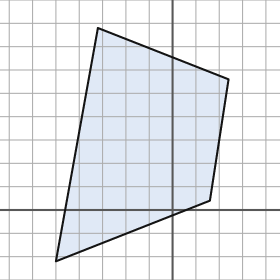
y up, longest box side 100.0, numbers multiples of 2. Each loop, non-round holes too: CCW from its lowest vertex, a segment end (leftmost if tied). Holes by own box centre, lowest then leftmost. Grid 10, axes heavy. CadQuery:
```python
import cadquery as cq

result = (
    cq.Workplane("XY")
    .moveTo(-50.0, -22.0)
    .lineTo(16.0, 4.0)
    .lineTo(24.0, 56.0)
    .lineTo(-32.0, 78.0)
    .close()
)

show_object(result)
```